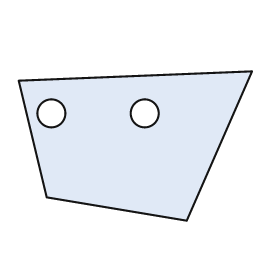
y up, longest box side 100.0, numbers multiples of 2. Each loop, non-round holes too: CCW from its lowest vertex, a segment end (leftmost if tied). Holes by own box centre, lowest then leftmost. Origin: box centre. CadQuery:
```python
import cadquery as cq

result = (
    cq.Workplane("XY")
    .moveTo(22.0, -32.0)
    .lineTo(50.0, 32.0)
    .lineTo(-50.0, 28.0)
    .lineTo(-38.0, -22.0)
    .close()
    .moveTo(-36.0, 14.0)
    .circle(6.0)
    .moveTo(4.0, 14.0)
    .circle(6.0)
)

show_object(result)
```